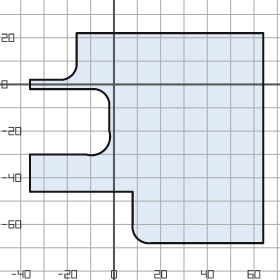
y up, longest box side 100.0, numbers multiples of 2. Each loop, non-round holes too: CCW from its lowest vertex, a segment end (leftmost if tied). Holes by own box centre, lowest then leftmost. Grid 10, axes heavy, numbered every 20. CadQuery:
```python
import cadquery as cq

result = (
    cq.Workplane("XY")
    .moveTo(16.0, -68.0)
    .lineTo(64.0, -68.0)
    .lineTo(64.0, 22.0)
    .lineTo(-16.0, 22.0)
    .lineTo(-16.0, 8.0)
    .threePointArc((-18.0, 4.0), (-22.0, 2.0))
    .lineTo(-36.0, 2.0)
    .lineTo(-36.0, -2.0)
    .lineTo(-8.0, -2.0)
    .threePointArc((-4.0, -4.0), (-2.0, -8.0))
    .lineTo(-2.0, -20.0)
    .threePointArc((-4.0, -28.0), (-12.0, -30.0))
    .lineTo(-36.0, -30.0)
    .lineTo(-36.0, -46.0)
    .lineTo(8.0, -46.0)
    .lineTo(8.0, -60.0)
    .threePointArc((10.0, -66.0), (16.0, -68.0))
    .close()
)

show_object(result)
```